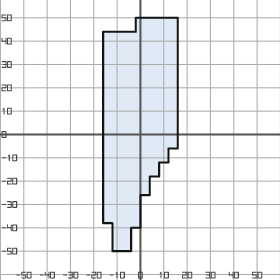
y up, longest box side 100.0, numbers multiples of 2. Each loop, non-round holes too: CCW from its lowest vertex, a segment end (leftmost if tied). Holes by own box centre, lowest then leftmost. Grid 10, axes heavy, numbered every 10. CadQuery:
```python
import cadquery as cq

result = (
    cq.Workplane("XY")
    .moveTo(-12.0, -50.0)
    .lineTo(-4.0, -50.0)
    .lineTo(-4.0, -40.0)
    .lineTo(0.0, -40.0)
    .lineTo(0.0, -26.0)
    .lineTo(4.0, -26.0)
    .lineTo(4.0, -18.0)
    .lineTo(8.0, -18.0)
    .lineTo(8.0, -12.0)
    .lineTo(12.0, -12.0)
    .lineTo(12.0, -6.0)
    .lineTo(16.0, -6.0)
    .lineTo(16.0, 50.0)
    .lineTo(-2.0, 50.0)
    .lineTo(-2.0, 44.0)
    .lineTo(-16.0, 44.0)
    .lineTo(-16.0, -38.0)
    .lineTo(-12.0, -38.0)
    .close()
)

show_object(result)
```